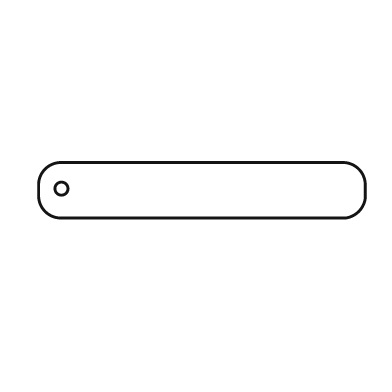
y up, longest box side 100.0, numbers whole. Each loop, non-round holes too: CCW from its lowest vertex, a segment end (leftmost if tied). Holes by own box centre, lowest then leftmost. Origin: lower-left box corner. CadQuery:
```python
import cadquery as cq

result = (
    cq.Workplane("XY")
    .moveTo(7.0, 0.0)
    .lineTo(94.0, 0.0)
    .threePointArc((98.0, 2.0), (100.0, 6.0))
    .lineTo(100.0, 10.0)
    .threePointArc((98.0, 15.0), (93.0, 17.0))
    .lineTo(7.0, 17.0)
    .threePointArc((2.0, 15.0), (0.0, 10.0))
    .lineTo(0.0, 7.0)
    .threePointArc((2.0, 2.0), (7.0, 0.0))
    .close()
    .moveTo(7.0, 9.0)
    .circle(2.0)
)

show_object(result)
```